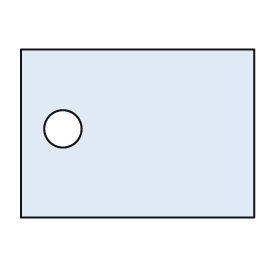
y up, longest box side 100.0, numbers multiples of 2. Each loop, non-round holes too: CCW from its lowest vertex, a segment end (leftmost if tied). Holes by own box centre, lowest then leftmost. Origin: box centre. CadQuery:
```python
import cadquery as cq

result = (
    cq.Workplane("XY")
    .moveTo(-50.0, -36.0)
    .lineTo(50.0, -36.0)
    .lineTo(50.0, 36.0)
    .lineTo(-50.0, 36.0)
    .close()
    .moveTo(-32.0, 2.0)
    .circle(8.0)
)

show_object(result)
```